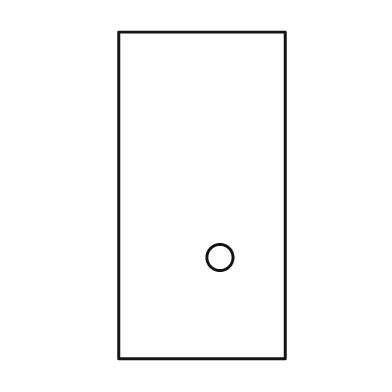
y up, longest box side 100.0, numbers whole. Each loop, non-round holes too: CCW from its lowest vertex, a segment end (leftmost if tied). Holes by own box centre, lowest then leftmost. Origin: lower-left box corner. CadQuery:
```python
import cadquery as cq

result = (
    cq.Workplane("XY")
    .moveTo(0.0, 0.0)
    .lineTo(51.0, 0.0)
    .lineTo(51.0, 100.0)
    .lineTo(0.0, 100.0)
    .close()
    .moveTo(31.0, 31.0)
    .circle(4.0)
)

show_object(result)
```